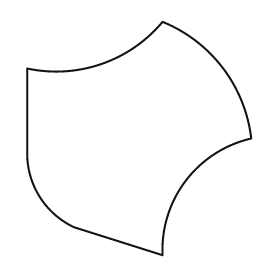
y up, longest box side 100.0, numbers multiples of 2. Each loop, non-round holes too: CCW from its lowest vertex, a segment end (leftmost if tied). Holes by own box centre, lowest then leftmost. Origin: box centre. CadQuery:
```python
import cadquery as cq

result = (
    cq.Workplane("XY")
    .moveTo(10.0, -50.0)
    .threePointArc((20.0, -18.0), (48.0, 0.0))
    .threePointArc((36.0, 30.0), (10.0, 50.0))
    .threePointArc((-16.0, 32.0), (-48.0, 30.0))
    .lineTo(-48.0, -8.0)
    .threePointArc((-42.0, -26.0), (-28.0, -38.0))
    .close()
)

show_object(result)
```